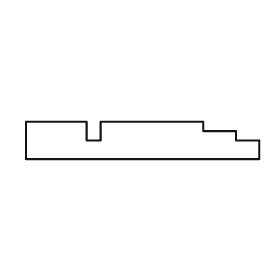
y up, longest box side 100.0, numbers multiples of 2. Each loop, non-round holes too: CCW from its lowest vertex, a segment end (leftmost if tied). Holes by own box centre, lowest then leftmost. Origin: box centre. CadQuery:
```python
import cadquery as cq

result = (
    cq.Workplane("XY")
    .moveTo(-50.0, -8.0)
    .lineTo(50.0, -8.0)
    .lineTo(50.0, 0.0)
    .lineTo(40.0, 0.0)
    .lineTo(40.0, 4.0)
    .lineTo(26.0, 4.0)
    .lineTo(26.0, 8.0)
    .lineTo(-18.0, 8.0)
    .lineTo(-18.0, 0.0)
    .lineTo(-24.0, 0.0)
    .lineTo(-24.0, 8.0)
    .lineTo(-50.0, 8.0)
    .close()
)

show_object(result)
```